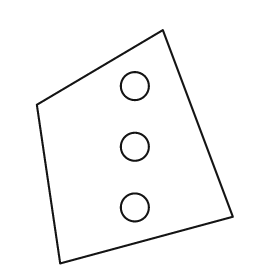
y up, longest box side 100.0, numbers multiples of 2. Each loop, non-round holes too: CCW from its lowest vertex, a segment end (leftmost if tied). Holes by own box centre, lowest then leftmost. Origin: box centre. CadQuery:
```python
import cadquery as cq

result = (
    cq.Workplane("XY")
    .moveTo(-32.0, -50.0)
    .lineTo(42.0, -30.0)
    .lineTo(12.0, 50.0)
    .lineTo(-42.0, 18.0)
    .close()
    .moveTo(0.0, -26.0)
    .circle(6.0)
    .moveTo(0.0, 0.0)
    .circle(6.0)
    .moveTo(0.0, 26.0)
    .circle(6.0)
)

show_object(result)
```